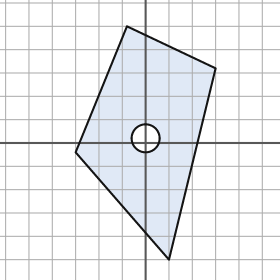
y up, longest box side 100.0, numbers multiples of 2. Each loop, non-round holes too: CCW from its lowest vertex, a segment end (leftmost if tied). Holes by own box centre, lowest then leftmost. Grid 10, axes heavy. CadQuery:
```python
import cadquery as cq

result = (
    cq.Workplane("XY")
    .moveTo(10.0, -50.0)
    .lineTo(30.0, 32.0)
    .lineTo(-8.0, 50.0)
    .lineTo(-30.0, -4.0)
    .close()
    .moveTo(0.0, 2.0)
    .circle(6.0)
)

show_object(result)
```